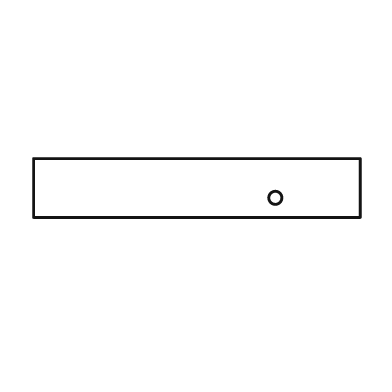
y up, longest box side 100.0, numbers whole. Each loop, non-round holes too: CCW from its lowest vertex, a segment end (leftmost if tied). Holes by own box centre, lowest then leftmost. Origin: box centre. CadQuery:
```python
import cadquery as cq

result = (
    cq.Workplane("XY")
    .moveTo(-50.0, -9.0)
    .lineTo(50.0, -9.0)
    .lineTo(50.0, 9.0)
    .lineTo(-50.0, 9.0)
    .close()
    .moveTo(24.0, -3.0)
    .circle(2.0)
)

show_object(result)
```